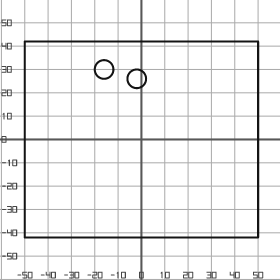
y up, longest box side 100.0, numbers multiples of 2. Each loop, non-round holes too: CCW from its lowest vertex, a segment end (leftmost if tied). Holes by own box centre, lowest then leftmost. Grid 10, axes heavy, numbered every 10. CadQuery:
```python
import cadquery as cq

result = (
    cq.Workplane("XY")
    .moveTo(-50.0, -42.0)
    .lineTo(50.0, -42.0)
    .lineTo(50.0, 42.0)
    .lineTo(-50.0, 42.0)
    .close()
    .moveTo(-2.0, 26.0)
    .circle(4.0)
    .moveTo(-16.0, 30.0)
    .circle(4.0)
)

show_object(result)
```